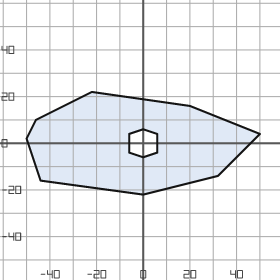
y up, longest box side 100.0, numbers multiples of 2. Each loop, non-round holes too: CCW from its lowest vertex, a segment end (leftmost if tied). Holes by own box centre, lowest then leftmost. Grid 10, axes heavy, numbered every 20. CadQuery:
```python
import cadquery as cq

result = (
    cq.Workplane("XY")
    .moveTo(0.0, -22.0)
    .lineTo(32.0, -14.0)
    .lineTo(50.0, 4.0)
    .lineTo(20.0, 16.0)
    .lineTo(-22.0, 22.0)
    .lineTo(-46.0, 10.0)
    .lineTo(-50.0, 2.0)
    .lineTo(-44.0, -16.0)
    .close()
    .moveTo(0.0, -6.0)
    .lineTo(6.0, -4.0)
    .lineTo(6.0, 4.0)
    .lineTo(0.0, 6.0)
    .lineTo(-6.0, 4.0)
    .lineTo(-6.0, -4.0)
    .close()
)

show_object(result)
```